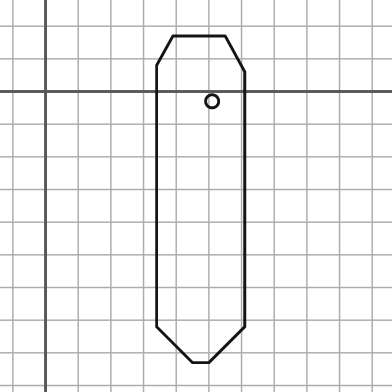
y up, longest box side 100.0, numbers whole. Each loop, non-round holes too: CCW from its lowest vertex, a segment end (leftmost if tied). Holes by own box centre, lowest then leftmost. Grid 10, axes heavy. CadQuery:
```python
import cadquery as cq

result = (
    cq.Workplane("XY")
    .moveTo(45.0, -83.0)
    .lineTo(50.0, -83.0)
    .lineTo(61.0, -72.0)
    .lineTo(61.0, 6.0)
    .lineTo(55.0, 17.0)
    .lineTo(39.0, 17.0)
    .lineTo(34.0, 8.0)
    .lineTo(34.0, -72.0)
    .close()
    .moveTo(51.0, -3.0)
    .circle(2.0)
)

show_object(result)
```